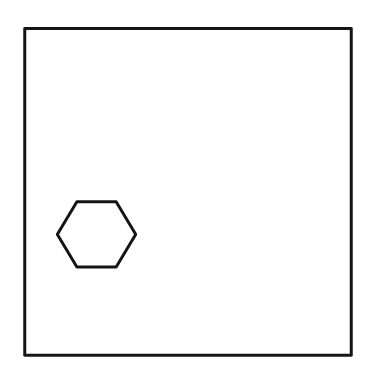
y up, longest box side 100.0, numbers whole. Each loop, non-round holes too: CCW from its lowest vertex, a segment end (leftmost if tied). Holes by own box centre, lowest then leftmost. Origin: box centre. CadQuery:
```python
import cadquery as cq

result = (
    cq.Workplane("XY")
    .moveTo(-50.0, -50.0)
    .lineTo(50.0, -50.0)
    .lineTo(50.0, 50.0)
    .lineTo(-50.0, 50.0)
    .close()
    .moveTo(-34.0, -23.0)
    .lineTo(-22.0, -23.0)
    .lineTo(-16.0, -13.0)
    .lineTo(-22.0, -3.0)
    .lineTo(-34.0, -3.0)
    .lineTo(-40.0, -13.0)
    .close()
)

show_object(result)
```